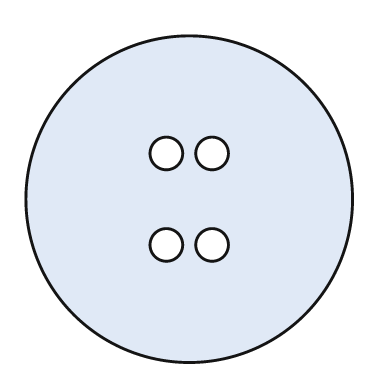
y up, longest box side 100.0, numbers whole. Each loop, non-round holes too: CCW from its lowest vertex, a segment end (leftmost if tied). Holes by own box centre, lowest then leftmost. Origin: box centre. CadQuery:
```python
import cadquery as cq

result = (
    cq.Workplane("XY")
    .moveTo(0.0, 0.0)
    .circle(50.0)
    .moveTo(-7.0, -14.0)
    .circle(5.0)
    .moveTo(7.0, -14.0)
    .circle(5.0)
    .moveTo(-7.0, 14.0)
    .circle(5.0)
    .moveTo(7.0, 14.0)
    .circle(5.0)
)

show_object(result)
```